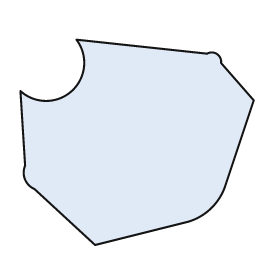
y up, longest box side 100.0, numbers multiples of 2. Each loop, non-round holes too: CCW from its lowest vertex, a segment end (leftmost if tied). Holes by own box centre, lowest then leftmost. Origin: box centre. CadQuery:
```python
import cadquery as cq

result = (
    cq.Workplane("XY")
    .moveTo(-18.0, -44.0)
    .lineTo(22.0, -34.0)
    .threePointArc((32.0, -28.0), (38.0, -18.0))
    .lineTo(50.0, 18.0)
    .lineTo(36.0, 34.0)
    .threePointArc((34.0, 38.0), (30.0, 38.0))
    .lineTo(-26.0, 44.0)
    .threePointArc((-28.0, 22.0), (-50.0, 22.0))
    .lineTo(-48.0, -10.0)
    .threePointArc((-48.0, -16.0), (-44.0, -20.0))
    .close()
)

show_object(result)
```